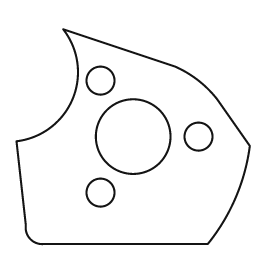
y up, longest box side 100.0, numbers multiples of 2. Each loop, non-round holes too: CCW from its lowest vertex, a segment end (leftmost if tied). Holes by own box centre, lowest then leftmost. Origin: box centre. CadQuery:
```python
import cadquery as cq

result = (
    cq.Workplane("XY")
    .moveTo(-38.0, -46.0)
    .lineTo(32.0, -46.0)
    .threePointArc((44.0, -26.0), (50.0, -4.0))
    .lineTo(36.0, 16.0)
    .threePointArc((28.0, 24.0), (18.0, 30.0))
    .lineTo(-30.0, 46.0)
    .threePointArc((-26.0, 16.0), (-50.0, -2.0))
    .lineTo(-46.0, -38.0)
    .threePointArc((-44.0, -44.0), (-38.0, -46.0))
    .close()
    .moveTo(-14.0, -24.0)
    .circle(6.0)
    .moveTo(0.0, 0.0)
    .circle(16.0)
    .moveTo(28.0, 0.0)
    .circle(6.0)
    .moveTo(-14.0, 24.0)
    .circle(6.0)
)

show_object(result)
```